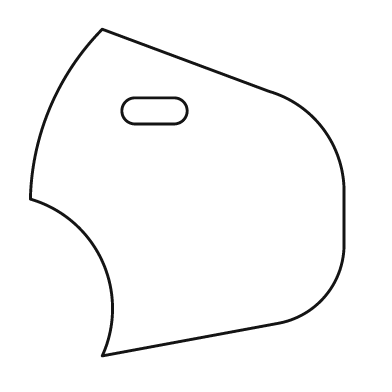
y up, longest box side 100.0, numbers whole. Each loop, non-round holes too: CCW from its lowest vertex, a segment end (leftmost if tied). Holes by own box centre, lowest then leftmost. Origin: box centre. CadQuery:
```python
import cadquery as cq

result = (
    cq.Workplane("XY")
    .moveTo(-26.0, -50.0)
    .lineTo(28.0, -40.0)
    .threePointArc((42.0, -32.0), (48.0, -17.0))
    .lineTo(48.0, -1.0)
    .threePointArc((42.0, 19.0), (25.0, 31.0))
    .lineTo(-26.0, 50.0)
    .threePointArc((-42.0, 26.0), (-48.0, -2.0))
    .threePointArc((-26.0, -21.0), (-26.0, -50.0))
    .close()
    .moveTo(-16.0, 21.0)
    .lineTo(-4.0, 21.0)
    .threePointArc((0.0, 25.0), (-4.0, 29.0))
    .lineTo(-16.0, 29.0)
    .threePointArc((-20.0, 25.0), (-16.0, 21.0))
    .close()
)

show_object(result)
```